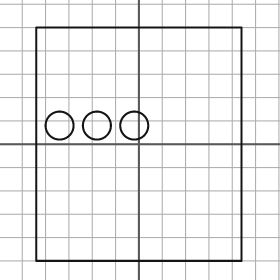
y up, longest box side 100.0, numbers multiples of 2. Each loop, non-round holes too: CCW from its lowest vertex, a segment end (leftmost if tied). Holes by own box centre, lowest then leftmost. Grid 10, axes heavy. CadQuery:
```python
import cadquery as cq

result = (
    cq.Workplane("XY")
    .moveTo(-44.0, -50.0)
    .lineTo(44.0, -50.0)
    .lineTo(44.0, 50.0)
    .lineTo(-44.0, 50.0)
    .close()
    .moveTo(-34.0, 8.0)
    .circle(6.0)
    .moveTo(-18.0, 8.0)
    .circle(6.0)
    .moveTo(-2.0, 8.0)
    .circle(6.0)
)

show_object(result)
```